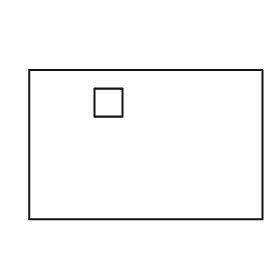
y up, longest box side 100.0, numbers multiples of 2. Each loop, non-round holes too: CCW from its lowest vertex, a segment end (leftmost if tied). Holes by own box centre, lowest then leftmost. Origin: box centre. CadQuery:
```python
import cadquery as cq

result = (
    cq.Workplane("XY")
    .moveTo(-50.0, -32.0)
    .lineTo(50.0, -32.0)
    .lineTo(50.0, 32.0)
    .lineTo(-50.0, 32.0)
    .close()
    .moveTo(-22.0, 12.0)
    .lineTo(-10.0, 12.0)
    .lineTo(-10.0, 24.0)
    .lineTo(-22.0, 24.0)
    .close()
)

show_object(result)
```